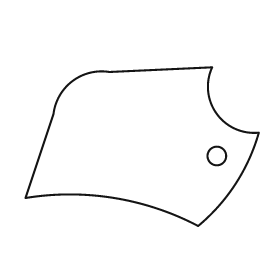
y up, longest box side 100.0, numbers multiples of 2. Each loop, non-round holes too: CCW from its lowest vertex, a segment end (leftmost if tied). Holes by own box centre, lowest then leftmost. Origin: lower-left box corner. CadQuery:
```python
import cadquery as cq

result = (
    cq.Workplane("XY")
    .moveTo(74.0, 0.0)
    .threePointArc((90.0, 18.0), (100.0, 40.0))
    .threePointArc((82.0, 48.0), (80.0, 68.0))
    .lineTo(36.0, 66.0)
    .threePointArc((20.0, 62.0), (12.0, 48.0))
    .lineTo(0.0, 12.0)
    .threePointArc((38.0, 12.0), (74.0, 0.0))
    .close()
    .moveTo(82.0, 30.0)
    .circle(4.0)
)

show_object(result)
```